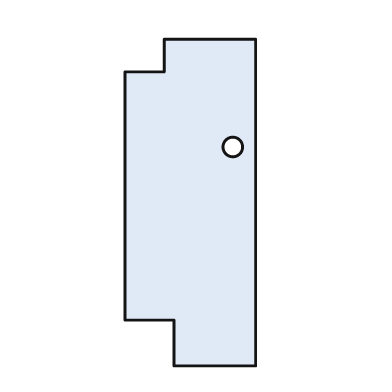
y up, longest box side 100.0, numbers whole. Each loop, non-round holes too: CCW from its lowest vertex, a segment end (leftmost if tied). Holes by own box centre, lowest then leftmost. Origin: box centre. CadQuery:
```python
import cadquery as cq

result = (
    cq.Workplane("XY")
    .moveTo(-5.0, -50.0)
    .lineTo(20.0, -50.0)
    .lineTo(20.0, 50.0)
    .lineTo(-8.0, 50.0)
    .lineTo(-8.0, 40.0)
    .lineTo(-20.0, 40.0)
    .lineTo(-20.0, -36.0)
    .lineTo(-5.0, -36.0)
    .close()
    .moveTo(13.0, 17.0)
    .circle(3.0)
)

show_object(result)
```